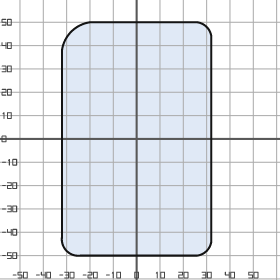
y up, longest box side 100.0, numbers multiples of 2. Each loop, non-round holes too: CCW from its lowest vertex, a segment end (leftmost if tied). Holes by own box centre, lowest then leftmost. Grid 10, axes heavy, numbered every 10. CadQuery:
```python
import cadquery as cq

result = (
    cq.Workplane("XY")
    .moveTo(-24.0, -50.0)
    .lineTo(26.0, -50.0)
    .threePointArc((30.0, -48.0), (32.0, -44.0))
    .lineTo(32.0, 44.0)
    .threePointArc((30.0, 48.0), (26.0, 50.0))
    .lineTo(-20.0, 50.0)
    .threePointArc((-28.0, 46.0), (-32.0, 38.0))
    .lineTo(-32.0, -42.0)
    .threePointArc((-30.0, -48.0), (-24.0, -50.0))
    .close()
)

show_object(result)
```